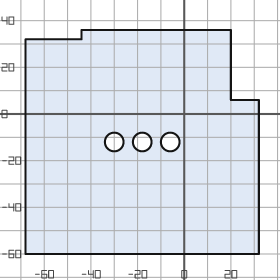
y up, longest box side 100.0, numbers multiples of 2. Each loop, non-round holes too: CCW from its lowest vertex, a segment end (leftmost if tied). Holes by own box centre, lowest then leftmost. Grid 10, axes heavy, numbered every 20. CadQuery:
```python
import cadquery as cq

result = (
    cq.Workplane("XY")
    .moveTo(-68.0, -60.0)
    .lineTo(32.0, -60.0)
    .lineTo(32.0, 6.0)
    .lineTo(20.0, 6.0)
    .lineTo(20.0, 36.0)
    .lineTo(-44.0, 36.0)
    .lineTo(-44.0, 32.0)
    .lineTo(-68.0, 32.0)
    .close()
    .moveTo(-30.0, -12.0)
    .circle(4.0)
    .moveTo(-18.0, -12.0)
    .circle(4.0)
    .moveTo(-6.0, -12.0)
    .circle(4.0)
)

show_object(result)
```